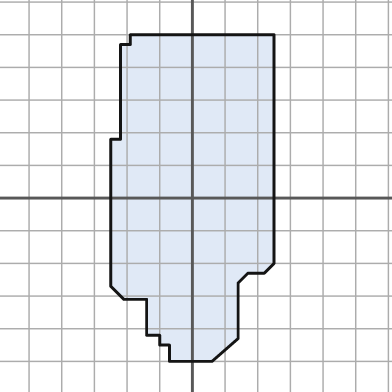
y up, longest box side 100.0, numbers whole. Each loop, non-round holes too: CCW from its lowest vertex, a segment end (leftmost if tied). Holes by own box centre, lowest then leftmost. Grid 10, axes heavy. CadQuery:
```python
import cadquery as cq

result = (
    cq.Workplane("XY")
    .moveTo(-7.0, -50.0)
    .lineTo(6.0, -50.0)
    .lineTo(14.0, -43.0)
    .lineTo(14.0, -26.0)
    .lineTo(17.0, -23.0)
    .lineTo(22.0, -23.0)
    .lineTo(25.0, -20.0)
    .lineTo(25.0, 50.0)
    .lineTo(-19.0, 50.0)
    .lineTo(-19.0, 47.0)
    .lineTo(-22.0, 47.0)
    .lineTo(-22.0, 18.0)
    .lineTo(-25.0, 18.0)
    .lineTo(-25.0, -27.0)
    .lineTo(-21.0, -31.0)
    .lineTo(-14.0, -31.0)
    .lineTo(-14.0, -42.0)
    .lineTo(-10.0, -42.0)
    .lineTo(-10.0, -45.0)
    .lineTo(-7.0, -45.0)
    .close()
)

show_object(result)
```